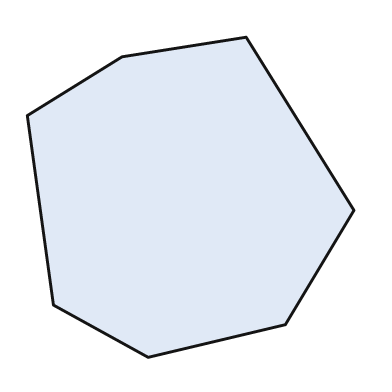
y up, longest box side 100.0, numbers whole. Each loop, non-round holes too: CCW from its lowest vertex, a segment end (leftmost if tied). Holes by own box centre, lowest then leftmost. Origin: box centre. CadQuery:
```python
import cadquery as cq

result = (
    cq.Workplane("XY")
    .moveTo(-13.0, -49.0)
    .lineTo(29.0, -39.0)
    .lineTo(50.0, -4.0)
    .lineTo(17.0, 49.0)
    .lineTo(-21.0, 43.0)
    .lineTo(-50.0, 25.0)
    .lineTo(-42.0, -33.0)
    .close()
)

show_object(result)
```